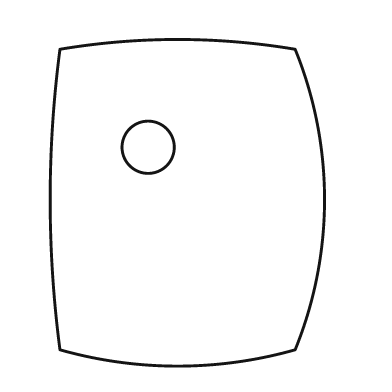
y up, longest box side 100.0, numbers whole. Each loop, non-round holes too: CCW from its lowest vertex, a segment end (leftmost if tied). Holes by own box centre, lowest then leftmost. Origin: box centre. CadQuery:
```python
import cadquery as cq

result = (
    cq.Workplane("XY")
    .moveTo(-39.0, -45.0)
    .threePointArc((-3.0, -50.0), (33.0, -45.0))
    .threePointArc((42.0, 1.0), (33.0, 47.0))
    .threePointArc((-3.0, 50.0), (-39.0, 47.0))
    .threePointArc((-42.0, 1.0), (-39.0, -45.0))
    .close()
    .moveTo(-12.0, 17.0)
    .circle(8.0)
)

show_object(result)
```